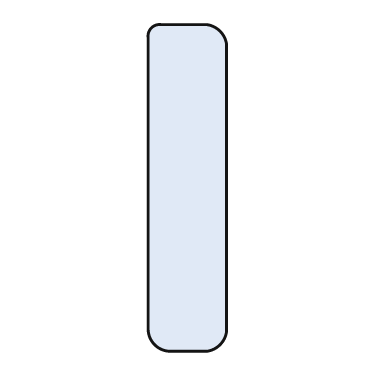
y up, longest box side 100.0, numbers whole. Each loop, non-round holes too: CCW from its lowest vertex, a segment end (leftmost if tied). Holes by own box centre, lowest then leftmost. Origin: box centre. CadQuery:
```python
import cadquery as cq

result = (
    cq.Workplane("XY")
    .moveTo(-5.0, -50.0)
    .lineTo(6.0, -50.0)
    .threePointArc((10.0, -48.0), (12.0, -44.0))
    .lineTo(12.0, 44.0)
    .threePointArc((10.0, 48.0), (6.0, 50.0))
    .lineTo(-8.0, 50.0)
    .threePointArc((-11.0, 49.0), (-12.0, 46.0))
    .lineTo(-12.0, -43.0)
    .threePointArc((-10.0, -48.0), (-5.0, -50.0))
    .close()
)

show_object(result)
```